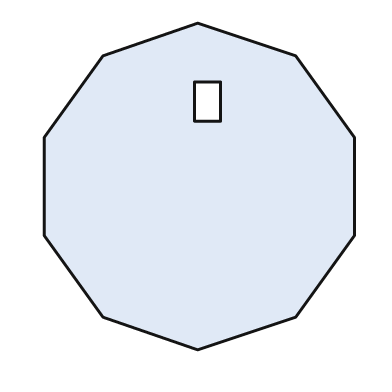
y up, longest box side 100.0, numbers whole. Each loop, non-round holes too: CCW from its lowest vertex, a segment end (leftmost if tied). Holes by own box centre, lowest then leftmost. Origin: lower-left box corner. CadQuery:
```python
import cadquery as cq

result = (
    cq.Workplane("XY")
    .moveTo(47.0, 0.0)
    .lineTo(77.0, 10.0)
    .lineTo(95.0, 35.0)
    .lineTo(95.0, 65.0)
    .lineTo(77.0, 90.0)
    .lineTo(47.0, 100.0)
    .lineTo(18.0, 90.0)
    .lineTo(0.0, 65.0)
    .lineTo(0.0, 35.0)
    .lineTo(18.0, 10.0)
    .close()
    .moveTo(46.0, 70.0)
    .lineTo(54.0, 70.0)
    .lineTo(54.0, 82.0)
    .lineTo(46.0, 82.0)
    .close()
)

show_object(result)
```